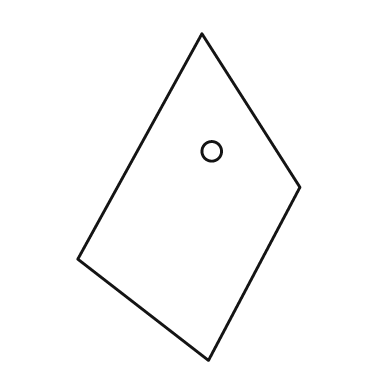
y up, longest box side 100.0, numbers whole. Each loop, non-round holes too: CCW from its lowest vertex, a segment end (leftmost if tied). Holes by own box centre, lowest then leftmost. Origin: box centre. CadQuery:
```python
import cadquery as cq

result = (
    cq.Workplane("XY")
    .moveTo(6.0, -50.0)
    .lineTo(34.0, 3.0)
    .lineTo(4.0, 50.0)
    .lineTo(-34.0, -19.0)
    .close()
    .moveTo(7.0, 14.0)
    .circle(3.0)
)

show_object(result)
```